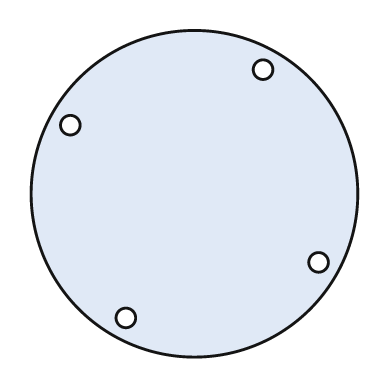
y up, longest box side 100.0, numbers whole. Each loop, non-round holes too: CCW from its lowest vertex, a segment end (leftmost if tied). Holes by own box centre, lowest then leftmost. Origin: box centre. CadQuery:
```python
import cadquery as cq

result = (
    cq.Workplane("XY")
    .moveTo(0.0, 0.0)
    .circle(50.0)
    .moveTo(-21.0, -38.0)
    .circle(3.0)
    .moveTo(38.0, -21.0)
    .circle(3.0)
    .moveTo(-38.0, 21.0)
    .circle(3.0)
    .moveTo(21.0, 38.0)
    .circle(3.0)
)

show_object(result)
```